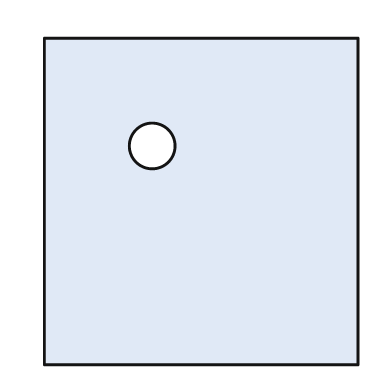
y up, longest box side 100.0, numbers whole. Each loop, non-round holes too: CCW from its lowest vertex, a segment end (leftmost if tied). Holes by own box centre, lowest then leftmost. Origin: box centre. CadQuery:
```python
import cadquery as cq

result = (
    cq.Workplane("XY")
    .moveTo(-48.0, -50.0)
    .lineTo(48.0, -50.0)
    .lineTo(48.0, 50.0)
    .lineTo(-48.0, 50.0)
    .close()
    .moveTo(-15.0, 17.0)
    .circle(7.0)
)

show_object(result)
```